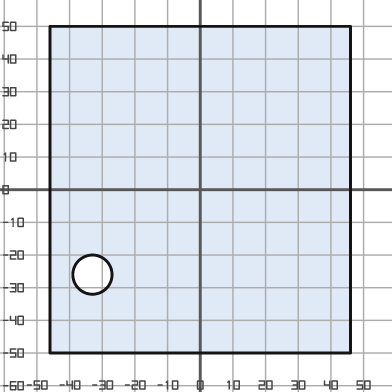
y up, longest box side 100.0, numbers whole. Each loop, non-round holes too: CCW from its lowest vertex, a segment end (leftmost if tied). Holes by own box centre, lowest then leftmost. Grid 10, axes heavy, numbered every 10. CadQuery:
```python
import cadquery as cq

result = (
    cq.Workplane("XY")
    .moveTo(-46.0, -50.0)
    .lineTo(46.0, -50.0)
    .lineTo(46.0, 50.0)
    .lineTo(-46.0, 50.0)
    .close()
    .moveTo(-33.0, -26.0)
    .circle(6.0)
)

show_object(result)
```